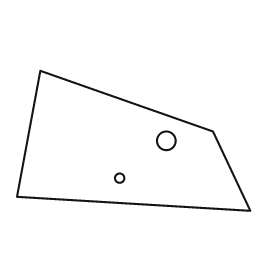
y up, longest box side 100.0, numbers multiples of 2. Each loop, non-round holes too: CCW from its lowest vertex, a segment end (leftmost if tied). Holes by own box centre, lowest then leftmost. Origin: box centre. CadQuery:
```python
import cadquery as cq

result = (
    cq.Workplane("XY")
    .moveTo(50.0, -30.0)
    .lineTo(34.0, 4.0)
    .lineTo(-40.0, 30.0)
    .lineTo(-50.0, -24.0)
    .close()
    .moveTo(-6.0, -16.0)
    .circle(2.0)
    .moveTo(14.0, 0.0)
    .circle(4.0)
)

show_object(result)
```